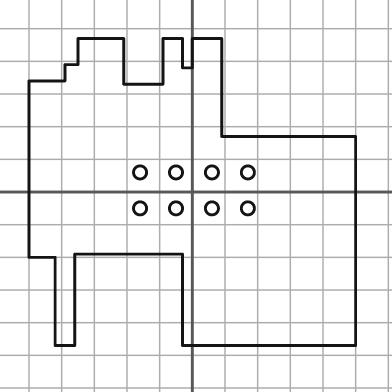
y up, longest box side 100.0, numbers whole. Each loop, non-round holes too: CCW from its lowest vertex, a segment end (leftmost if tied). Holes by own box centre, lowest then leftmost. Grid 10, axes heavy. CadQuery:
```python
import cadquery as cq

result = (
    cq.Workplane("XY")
    .moveTo(-42.0, -47.0)
    .lineTo(-36.0, -47.0)
    .lineTo(-36.0, -19.0)
    .lineTo(-3.0, -19.0)
    .lineTo(-3.0, -47.0)
    .lineTo(50.0, -47.0)
    .lineTo(50.0, 17.0)
    .lineTo(9.0, 17.0)
    .lineTo(9.0, 47.0)
    .lineTo(0.0, 47.0)
    .lineTo(0.0, 38.0)
    .lineTo(-3.0, 38.0)
    .lineTo(-3.0, 47.0)
    .lineTo(-9.0, 47.0)
    .lineTo(-9.0, 33.0)
    .lineTo(-21.0, 33.0)
    .lineTo(-21.0, 47.0)
    .lineTo(-35.0, 47.0)
    .lineTo(-35.0, 39.0)
    .lineTo(-39.0, 39.0)
    .lineTo(-39.0, 34.0)
    .lineTo(-50.0, 34.0)
    .lineTo(-50.0, -20.0)
    .lineTo(-42.0, -20.0)
    .close()
    .moveTo(-16.0, -5.0)
    .circle(2.0)
    .moveTo(-5.0, -5.0)
    .circle(2.0)
    .moveTo(6.0, -5.0)
    .circle(2.0)
    .moveTo(17.0, -5.0)
    .circle(2.0)
    .moveTo(-16.0, 6.0)
    .circle(2.0)
    .moveTo(-5.0, 6.0)
    .circle(2.0)
    .moveTo(6.0, 6.0)
    .circle(2.0)
    .moveTo(17.0, 6.0)
    .circle(2.0)
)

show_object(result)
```